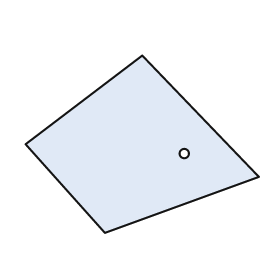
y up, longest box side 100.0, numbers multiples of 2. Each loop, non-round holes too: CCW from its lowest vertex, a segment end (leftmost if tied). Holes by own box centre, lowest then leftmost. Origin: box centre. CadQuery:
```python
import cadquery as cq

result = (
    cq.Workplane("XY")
    .moveTo(-16.0, -38.0)
    .lineTo(50.0, -14.0)
    .lineTo(0.0, 38.0)
    .lineTo(-50.0, 0.0)
    .close()
    .moveTo(18.0, -4.0)
    .circle(2.0)
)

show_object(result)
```